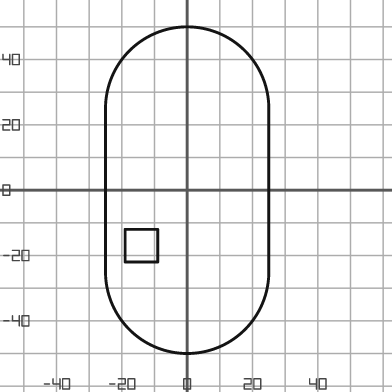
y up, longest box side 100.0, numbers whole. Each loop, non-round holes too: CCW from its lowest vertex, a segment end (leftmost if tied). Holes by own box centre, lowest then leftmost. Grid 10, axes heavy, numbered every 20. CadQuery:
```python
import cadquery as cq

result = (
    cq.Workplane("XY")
    .moveTo(-25.0, -25.0)
    .threePointArc((0.0, -50.0), (25.0, -25.0))
    .lineTo(25.0, 25.0)
    .threePointArc((0.0, 50.0), (-25.0, 25.0))
    .close()
    .moveTo(-19.0, -22.0)
    .lineTo(-9.0, -22.0)
    .lineTo(-9.0, -12.0)
    .lineTo(-19.0, -12.0)
    .close()
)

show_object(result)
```